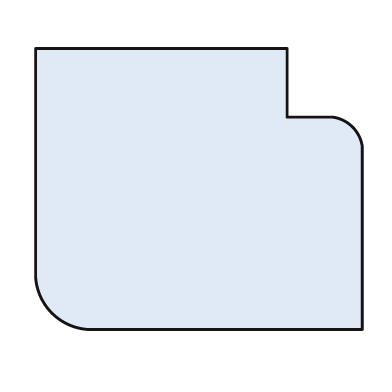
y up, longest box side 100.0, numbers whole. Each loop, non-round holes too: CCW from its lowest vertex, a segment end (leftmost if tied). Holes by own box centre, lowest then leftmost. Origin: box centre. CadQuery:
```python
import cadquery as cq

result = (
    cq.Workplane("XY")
    .moveTo(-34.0, -43.0)
    .lineTo(50.0, -43.0)
    .lineTo(50.0, 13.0)
    .threePointArc((47.0, 19.0), (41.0, 22.0))
    .lineTo(27.0, 22.0)
    .lineTo(27.0, 43.0)
    .lineTo(-50.0, 43.0)
    .lineTo(-50.0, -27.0)
    .threePointArc((-45.0, -38.0), (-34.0, -43.0))
    .close()
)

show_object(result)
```